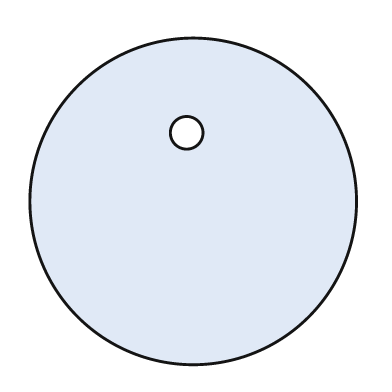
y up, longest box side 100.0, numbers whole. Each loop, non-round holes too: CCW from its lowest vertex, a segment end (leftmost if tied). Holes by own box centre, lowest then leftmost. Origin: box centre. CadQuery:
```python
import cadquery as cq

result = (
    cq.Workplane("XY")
    .moveTo(0.0, 0.0)
    .circle(50.0)
    .moveTo(-2.0, 21.0)
    .circle(5.0)
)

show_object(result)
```